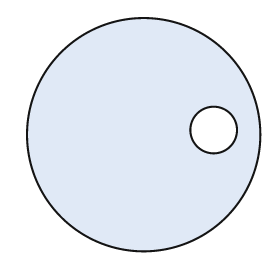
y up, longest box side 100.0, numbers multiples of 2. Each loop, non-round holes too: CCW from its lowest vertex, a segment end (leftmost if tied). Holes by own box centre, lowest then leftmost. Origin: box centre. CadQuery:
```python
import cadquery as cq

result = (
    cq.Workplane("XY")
    .moveTo(0.0, 0.0)
    .circle(50.0)
    .moveTo(30.0, 2.0)
    .circle(10.0)
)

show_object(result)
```